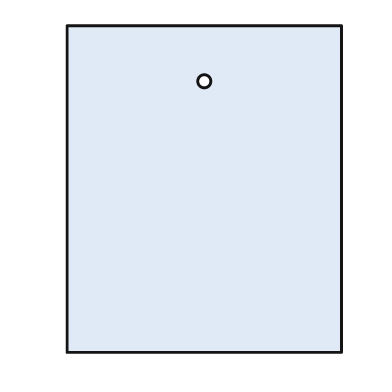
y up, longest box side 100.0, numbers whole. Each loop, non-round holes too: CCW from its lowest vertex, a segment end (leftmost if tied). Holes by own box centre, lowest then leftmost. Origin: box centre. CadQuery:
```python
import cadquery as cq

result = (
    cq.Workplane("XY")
    .moveTo(-42.0, -50.0)
    .lineTo(42.0, -50.0)
    .lineTo(42.0, 50.0)
    .lineTo(-42.0, 50.0)
    .close()
    .moveTo(0.0, 33.0)
    .circle(2.0)
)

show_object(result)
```